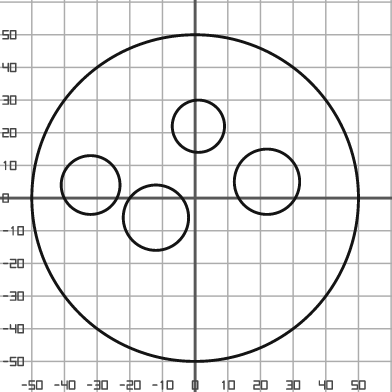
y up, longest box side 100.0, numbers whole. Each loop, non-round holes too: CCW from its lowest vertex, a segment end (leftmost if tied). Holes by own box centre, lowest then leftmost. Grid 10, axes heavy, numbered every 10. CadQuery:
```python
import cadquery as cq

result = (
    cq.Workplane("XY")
    .moveTo(0.0, 0.0)
    .circle(50.0)
    .moveTo(-12.0, -6.0)
    .circle(10.0)
    .moveTo(-32.0, 4.0)
    .circle(9.0)
    .moveTo(22.0, 5.0)
    .circle(10.0)
    .moveTo(1.0, 22.0)
    .circle(8.0)
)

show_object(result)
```